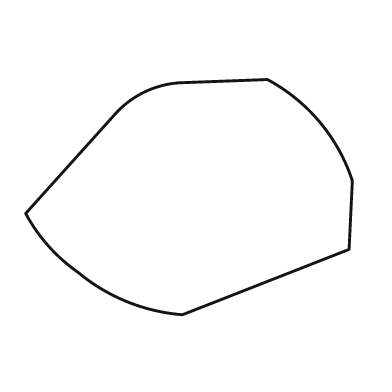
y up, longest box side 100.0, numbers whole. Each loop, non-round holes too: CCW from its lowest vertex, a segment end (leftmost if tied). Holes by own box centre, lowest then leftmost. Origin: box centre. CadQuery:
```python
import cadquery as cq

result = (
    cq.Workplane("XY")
    .moveTo(-2.0, -36.0)
    .lineTo(49.0, -16.0)
    .lineTo(50.0, 5.0)
    .threePointArc((40.0, 23.0), (24.0, 36.0))
    .lineTo(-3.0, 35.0)
    .threePointArc((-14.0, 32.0), (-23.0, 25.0))
    .lineTo(-50.0, -5.0)
    .threePointArc((-43.0, -15.0), (-34.0, -23.0))
    .threePointArc((-19.0, -32.0), (-2.0, -36.0))
    .close()
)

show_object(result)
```